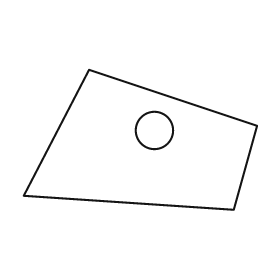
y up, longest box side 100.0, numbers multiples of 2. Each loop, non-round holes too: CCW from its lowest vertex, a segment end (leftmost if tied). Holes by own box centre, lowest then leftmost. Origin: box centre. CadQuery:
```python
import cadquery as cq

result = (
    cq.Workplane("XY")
    .moveTo(40.0, -30.0)
    .lineTo(50.0, 6.0)
    .lineTo(-22.0, 30.0)
    .lineTo(-50.0, -24.0)
    .close()
    .moveTo(6.0, 4.0)
    .circle(8.0)
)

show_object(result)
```